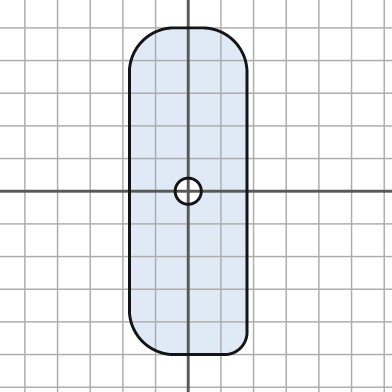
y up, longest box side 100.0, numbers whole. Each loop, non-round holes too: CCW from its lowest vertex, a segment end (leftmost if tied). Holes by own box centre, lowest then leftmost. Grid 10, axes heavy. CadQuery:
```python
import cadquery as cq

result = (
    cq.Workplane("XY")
    .moveTo(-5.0, -50.0)
    .lineTo(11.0, -50.0)
    .threePointArc((16.0, -48.0), (18.0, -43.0))
    .lineTo(18.0, 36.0)
    .threePointArc((14.0, 46.0), (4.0, 50.0))
    .lineTo(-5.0, 50.0)
    .threePointArc((-14.0, 46.0), (-18.0, 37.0))
    .lineTo(-18.0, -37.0)
    .threePointArc((-14.0, -46.0), (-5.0, -50.0))
    .close()
    .moveTo(0.0, 0.0)
    .circle(4.0)
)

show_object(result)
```